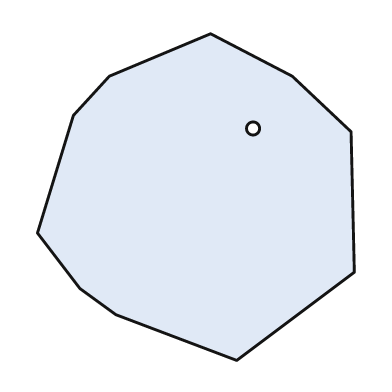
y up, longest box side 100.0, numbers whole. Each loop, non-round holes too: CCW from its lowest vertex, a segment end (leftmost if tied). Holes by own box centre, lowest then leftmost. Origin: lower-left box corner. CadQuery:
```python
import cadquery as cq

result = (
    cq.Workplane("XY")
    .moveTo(61.0, 0.0)
    .lineTo(97.0, 27.0)
    .lineTo(96.0, 70.0)
    .lineTo(78.0, 87.0)
    .lineTo(53.0, 100.0)
    .lineTo(22.0, 87.0)
    .lineTo(11.0, 75.0)
    .lineTo(0.0, 39.0)
    .lineTo(13.0, 22.0)
    .lineTo(24.0, 14.0)
    .close()
    .moveTo(66.0, 71.0)
    .circle(2.0)
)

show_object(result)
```